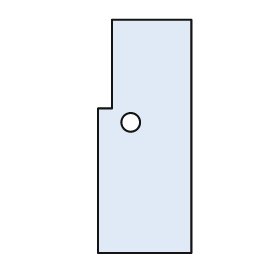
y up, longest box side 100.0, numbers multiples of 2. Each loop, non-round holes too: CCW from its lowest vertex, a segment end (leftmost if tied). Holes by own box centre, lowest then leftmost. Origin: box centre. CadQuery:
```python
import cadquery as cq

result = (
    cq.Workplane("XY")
    .moveTo(-20.0, -50.0)
    .lineTo(20.0, -50.0)
    .lineTo(20.0, 50.0)
    .lineTo(-14.0, 50.0)
    .lineTo(-14.0, 12.0)
    .lineTo(-20.0, 12.0)
    .close()
    .moveTo(-6.0, 6.0)
    .circle(4.0)
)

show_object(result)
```